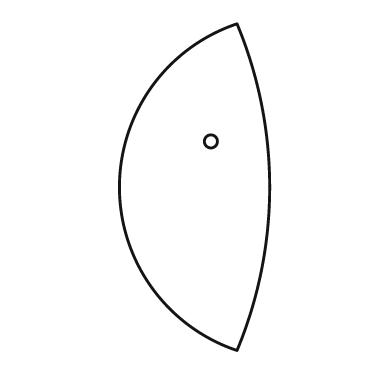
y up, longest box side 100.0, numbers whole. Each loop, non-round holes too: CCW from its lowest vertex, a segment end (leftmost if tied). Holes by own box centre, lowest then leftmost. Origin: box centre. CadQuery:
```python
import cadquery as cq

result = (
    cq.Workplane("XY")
    .moveTo(13.0, -50.0)
    .threePointArc((23.0, 0.0), (13.0, 50.0))
    .threePointArc((-23.0, 0.0), (13.0, -50.0))
    .close()
    .moveTo(5.0, 14.0)
    .circle(2.0)
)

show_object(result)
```